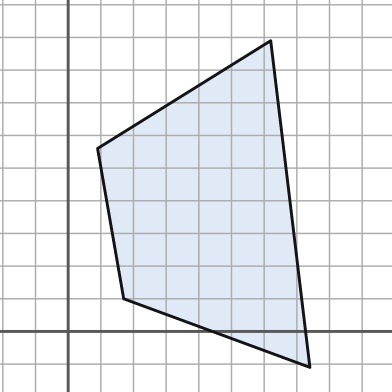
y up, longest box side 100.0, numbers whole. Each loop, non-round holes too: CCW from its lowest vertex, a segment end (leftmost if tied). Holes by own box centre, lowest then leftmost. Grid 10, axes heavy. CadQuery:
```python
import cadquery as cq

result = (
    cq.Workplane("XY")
    .moveTo(74.0, -11.0)
    .lineTo(62.0, 89.0)
    .lineTo(9.0, 56.0)
    .lineTo(17.0, 10.0)
    .close()
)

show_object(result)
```